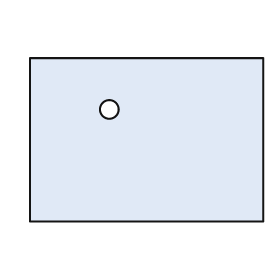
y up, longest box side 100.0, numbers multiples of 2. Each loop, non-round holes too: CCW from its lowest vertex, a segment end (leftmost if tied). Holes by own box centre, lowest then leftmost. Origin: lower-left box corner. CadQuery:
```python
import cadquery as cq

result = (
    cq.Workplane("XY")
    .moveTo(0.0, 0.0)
    .lineTo(100.0, 0.0)
    .lineTo(100.0, 70.0)
    .lineTo(0.0, 70.0)
    .close()
    .moveTo(34.0, 48.0)
    .circle(4.0)
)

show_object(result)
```